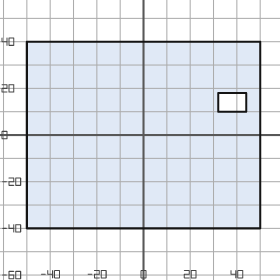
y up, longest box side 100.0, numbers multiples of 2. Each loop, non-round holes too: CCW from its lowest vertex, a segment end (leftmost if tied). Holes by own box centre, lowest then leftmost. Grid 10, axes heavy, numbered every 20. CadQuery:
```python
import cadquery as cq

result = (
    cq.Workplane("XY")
    .moveTo(-50.0, -40.0)
    .lineTo(50.0, -40.0)
    .lineTo(50.0, 40.0)
    .lineTo(-50.0, 40.0)
    .close()
    .moveTo(32.0, 10.0)
    .lineTo(44.0, 10.0)
    .lineTo(44.0, 18.0)
    .lineTo(32.0, 18.0)
    .close()
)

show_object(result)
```